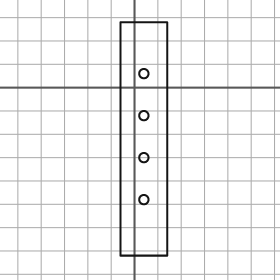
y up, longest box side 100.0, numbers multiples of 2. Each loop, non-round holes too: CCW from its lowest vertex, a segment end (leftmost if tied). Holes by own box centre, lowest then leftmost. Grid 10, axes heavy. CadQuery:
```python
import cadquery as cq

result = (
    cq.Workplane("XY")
    .moveTo(-6.0, -72.0)
    .lineTo(14.0, -72.0)
    .lineTo(14.0, 28.0)
    .lineTo(-6.0, 28.0)
    .close()
    .moveTo(4.0, -48.0)
    .circle(2.0)
    .moveTo(4.0, -30.0)
    .circle(2.0)
    .moveTo(4.0, -12.0)
    .circle(2.0)
    .moveTo(4.0, 6.0)
    .circle(2.0)
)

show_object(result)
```